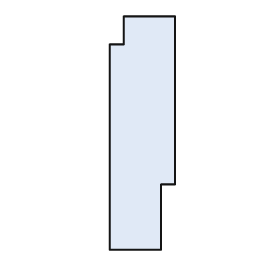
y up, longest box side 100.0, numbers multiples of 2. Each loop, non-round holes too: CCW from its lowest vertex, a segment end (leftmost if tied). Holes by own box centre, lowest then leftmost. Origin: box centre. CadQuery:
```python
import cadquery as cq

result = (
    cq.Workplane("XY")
    .moveTo(-14.0, -50.0)
    .lineTo(8.0, -50.0)
    .lineTo(8.0, -22.0)
    .lineTo(14.0, -22.0)
    .lineTo(14.0, 50.0)
    .lineTo(-8.0, 50.0)
    .lineTo(-8.0, 38.0)
    .lineTo(-14.0, 38.0)
    .close()
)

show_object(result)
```